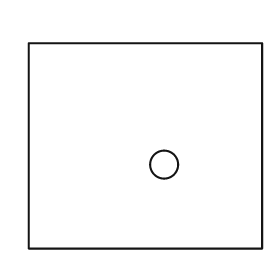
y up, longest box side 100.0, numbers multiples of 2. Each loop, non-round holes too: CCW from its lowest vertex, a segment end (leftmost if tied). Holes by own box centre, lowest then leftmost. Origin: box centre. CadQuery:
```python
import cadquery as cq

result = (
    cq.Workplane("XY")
    .moveTo(-50.0, -44.0)
    .lineTo(50.0, -44.0)
    .lineTo(50.0, 44.0)
    .lineTo(-50.0, 44.0)
    .close()
    .moveTo(8.0, -8.0)
    .circle(6.0)
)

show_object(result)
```